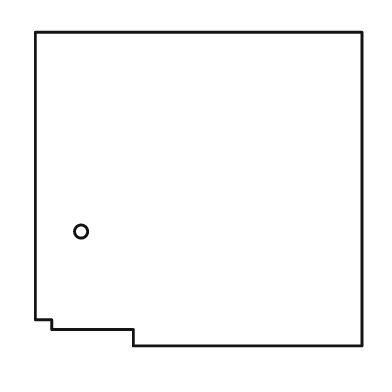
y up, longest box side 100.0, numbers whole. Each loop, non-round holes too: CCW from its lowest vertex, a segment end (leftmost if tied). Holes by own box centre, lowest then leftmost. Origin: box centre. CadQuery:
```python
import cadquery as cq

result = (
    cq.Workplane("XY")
    .moveTo(-20.0, -48.0)
    .lineTo(50.0, -48.0)
    .lineTo(50.0, 48.0)
    .lineTo(-50.0, 48.0)
    .lineTo(-50.0, -40.0)
    .lineTo(-45.0, -40.0)
    .lineTo(-45.0, -43.0)
    .lineTo(-20.0, -43.0)
    .close()
    .moveTo(-36.0, -13.0)
    .circle(2.0)
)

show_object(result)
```